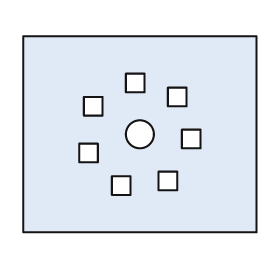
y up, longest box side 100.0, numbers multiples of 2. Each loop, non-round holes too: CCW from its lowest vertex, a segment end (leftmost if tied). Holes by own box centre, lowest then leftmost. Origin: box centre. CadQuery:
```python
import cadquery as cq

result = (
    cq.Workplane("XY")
    .moveTo(-50.0, -42.0)
    .lineTo(50.0, -42.0)
    .lineTo(50.0, 42.0)
    .lineTo(-50.0, 42.0)
    .close()
    .moveTo(-12.0, -26.0)
    .lineTo(-4.0, -26.0)
    .lineTo(-4.0, -18.0)
    .lineTo(-12.0, -18.0)
    .close()
    .moveTo(8.0, -24.0)
    .lineTo(16.0, -24.0)
    .lineTo(16.0, -16.0)
    .lineTo(8.0, -16.0)
    .close()
    .moveTo(-26.0, -12.0)
    .lineTo(-18.0, -12.0)
    .lineTo(-18.0, -4.0)
    .lineTo(-26.0, -4.0)
    .close()
    .moveTo(18.0, -6.0)
    .lineTo(26.0, -6.0)
    .lineTo(26.0, 2.0)
    .lineTo(18.0, 2.0)
    .close()
    .moveTo(0.0, 0.0)
    .circle(6.0)
    .moveTo(-24.0, 8.0)
    .lineTo(-16.0, 8.0)
    .lineTo(-16.0, 16.0)
    .lineTo(-24.0, 16.0)
    .close()
    .moveTo(12.0, 12.0)
    .lineTo(20.0, 12.0)
    .lineTo(20.0, 20.0)
    .lineTo(12.0, 20.0)
    .close()
    .moveTo(-6.0, 18.0)
    .lineTo(2.0, 18.0)
    .lineTo(2.0, 26.0)
    .lineTo(-6.0, 26.0)
    .close()
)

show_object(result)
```